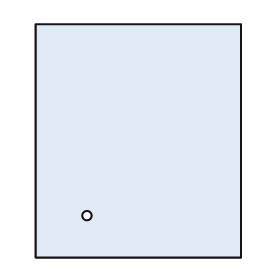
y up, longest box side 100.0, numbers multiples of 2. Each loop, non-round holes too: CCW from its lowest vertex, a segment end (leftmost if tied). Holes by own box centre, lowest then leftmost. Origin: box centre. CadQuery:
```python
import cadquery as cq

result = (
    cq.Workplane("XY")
    .moveTo(-44.0, -50.0)
    .lineTo(44.0, -50.0)
    .lineTo(44.0, 50.0)
    .lineTo(-44.0, 50.0)
    .close()
    .moveTo(-22.0, -32.0)
    .circle(2.0)
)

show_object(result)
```